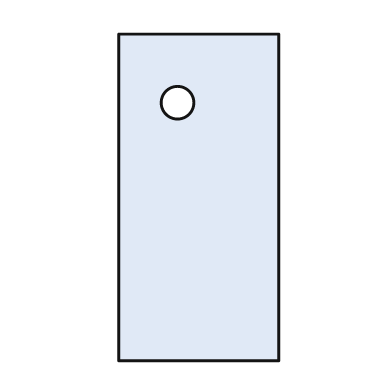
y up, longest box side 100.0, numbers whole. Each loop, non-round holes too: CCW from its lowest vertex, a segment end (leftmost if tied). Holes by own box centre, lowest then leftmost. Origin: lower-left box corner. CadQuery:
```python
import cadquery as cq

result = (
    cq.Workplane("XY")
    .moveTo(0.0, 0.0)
    .lineTo(49.0, 0.0)
    .lineTo(49.0, 100.0)
    .lineTo(0.0, 100.0)
    .close()
    .moveTo(18.0, 79.0)
    .circle(5.0)
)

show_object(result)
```